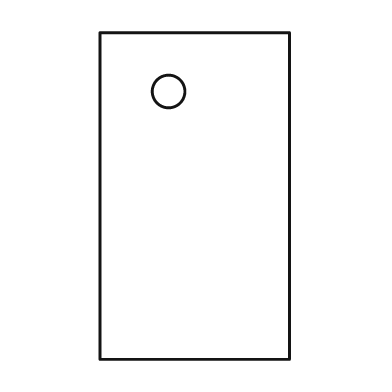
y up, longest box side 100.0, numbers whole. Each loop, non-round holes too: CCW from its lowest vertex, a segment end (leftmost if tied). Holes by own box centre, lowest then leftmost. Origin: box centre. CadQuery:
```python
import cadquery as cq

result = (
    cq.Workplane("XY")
    .moveTo(-29.0, -50.0)
    .lineTo(29.0, -50.0)
    .lineTo(29.0, 50.0)
    .lineTo(-29.0, 50.0)
    .close()
    .moveTo(-8.0, 32.0)
    .circle(5.0)
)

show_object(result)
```